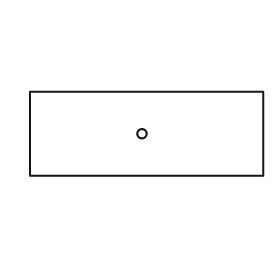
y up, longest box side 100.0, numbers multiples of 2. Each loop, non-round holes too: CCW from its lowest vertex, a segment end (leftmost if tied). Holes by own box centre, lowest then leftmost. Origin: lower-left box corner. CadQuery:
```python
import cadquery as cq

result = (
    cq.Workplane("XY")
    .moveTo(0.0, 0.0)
    .lineTo(100.0, 0.0)
    .lineTo(100.0, 36.0)
    .lineTo(0.0, 36.0)
    .close()
    .moveTo(48.0, 18.0)
    .circle(2.0)
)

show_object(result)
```